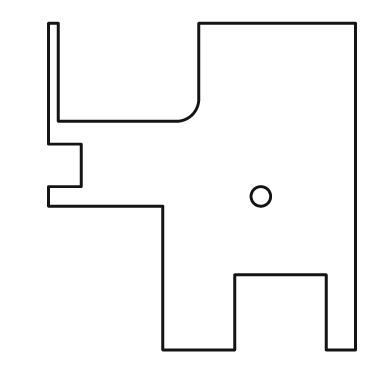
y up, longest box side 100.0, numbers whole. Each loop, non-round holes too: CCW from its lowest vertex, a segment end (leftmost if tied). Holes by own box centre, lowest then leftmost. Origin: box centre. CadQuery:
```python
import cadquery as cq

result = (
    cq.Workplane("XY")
    .moveTo(-12.0, -50.0)
    .lineTo(10.0, -50.0)
    .lineTo(10.0, -27.0)
    .lineTo(38.0, -27.0)
    .lineTo(38.0, -50.0)
    .lineTo(47.0, -50.0)
    .lineTo(47.0, 50.0)
    .lineTo(-1.0, 50.0)
    .lineTo(-1.0, 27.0)
    .threePointArc((-3.0, 22.0), (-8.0, 20.0))
    .lineTo(-44.0, 20.0)
    .lineTo(-44.0, 50.0)
    .lineTo(-47.0, 50.0)
    .lineTo(-47.0, 13.0)
    .lineTo(-37.0, 13.0)
    .lineTo(-37.0, 0.0)
    .lineTo(-47.0, 0.0)
    .lineTo(-47.0, -6.0)
    .lineTo(-12.0, -6.0)
    .close()
    .moveTo(18.0, -3.0)
    .circle(3.0)
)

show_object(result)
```